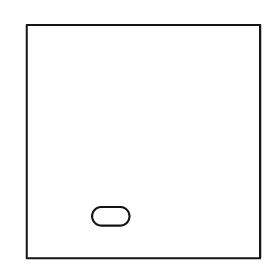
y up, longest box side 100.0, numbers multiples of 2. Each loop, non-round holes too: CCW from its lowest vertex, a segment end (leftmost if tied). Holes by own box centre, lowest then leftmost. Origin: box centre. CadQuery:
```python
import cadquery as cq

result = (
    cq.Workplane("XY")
    .moveTo(-50.0, -50.0)
    .lineTo(50.0, -50.0)
    .lineTo(50.0, 50.0)
    .lineTo(-50.0, 50.0)
    .close()
    .moveTo(-18.0, -36.0)
    .lineTo(-10.0, -36.0)
    .threePointArc((-6.0, -32.0), (-10.0, -28.0))
    .lineTo(-18.0, -28.0)
    .threePointArc((-22.0, -32.0), (-18.0, -36.0))
    .close()
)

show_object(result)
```